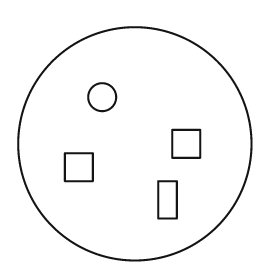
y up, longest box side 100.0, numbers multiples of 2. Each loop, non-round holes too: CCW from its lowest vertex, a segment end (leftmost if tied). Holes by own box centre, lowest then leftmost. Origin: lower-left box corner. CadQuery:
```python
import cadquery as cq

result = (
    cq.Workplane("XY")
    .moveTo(50.0, 50.0)
    .circle(50.0)
    .moveTo(60.0, 18.0)
    .lineTo(68.0, 18.0)
    .lineTo(68.0, 34.0)
    .lineTo(60.0, 34.0)
    .close()
    .moveTo(20.0, 34.0)
    .lineTo(32.0, 34.0)
    .lineTo(32.0, 46.0)
    .lineTo(20.0, 46.0)
    .close()
    .moveTo(66.0, 44.0)
    .lineTo(78.0, 44.0)
    .lineTo(78.0, 56.0)
    .lineTo(66.0, 56.0)
    .close()
    .moveTo(36.0, 70.0)
    .circle(6.0)
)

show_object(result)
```